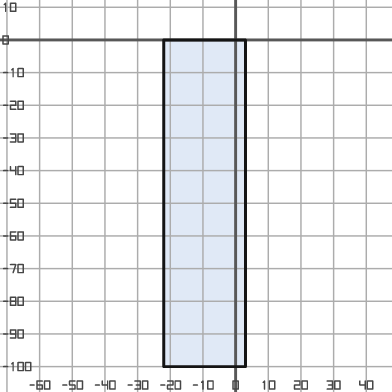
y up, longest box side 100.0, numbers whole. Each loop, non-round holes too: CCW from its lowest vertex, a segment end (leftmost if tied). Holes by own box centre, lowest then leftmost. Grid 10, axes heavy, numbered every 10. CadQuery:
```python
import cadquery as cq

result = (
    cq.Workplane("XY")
    .moveTo(-22.0, -100.0)
    .lineTo(3.0, -100.0)
    .lineTo(3.0, 0.0)
    .lineTo(-22.0, 0.0)
    .close()
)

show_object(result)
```